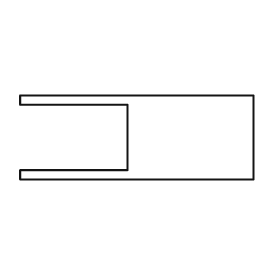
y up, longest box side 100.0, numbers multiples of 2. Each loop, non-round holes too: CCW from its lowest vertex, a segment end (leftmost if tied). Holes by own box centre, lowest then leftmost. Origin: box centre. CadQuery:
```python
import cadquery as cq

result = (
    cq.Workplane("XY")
    .moveTo(-50.0, -18.0)
    .lineTo(50.0, -18.0)
    .lineTo(50.0, 18.0)
    .lineTo(-50.0, 18.0)
    .lineTo(-50.0, 14.0)
    .lineTo(-4.0, 14.0)
    .lineTo(-4.0, -14.0)
    .lineTo(-50.0, -14.0)
    .close()
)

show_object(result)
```